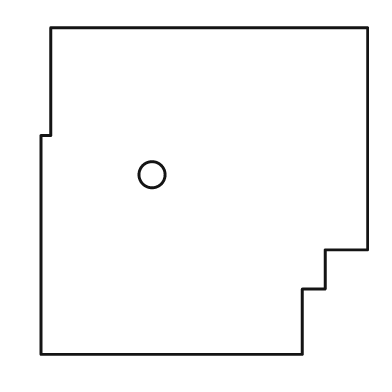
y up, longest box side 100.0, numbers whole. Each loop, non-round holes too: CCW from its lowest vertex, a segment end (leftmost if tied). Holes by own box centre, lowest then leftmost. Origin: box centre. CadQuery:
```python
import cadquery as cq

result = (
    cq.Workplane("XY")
    .moveTo(-50.0, -50.0)
    .lineTo(30.0, -50.0)
    .lineTo(30.0, -30.0)
    .lineTo(37.0, -30.0)
    .lineTo(37.0, -18.0)
    .lineTo(50.0, -18.0)
    .lineTo(50.0, 50.0)
    .lineTo(-47.0, 50.0)
    .lineTo(-47.0, 17.0)
    .lineTo(-50.0, 17.0)
    .close()
    .moveTo(-16.0, 5.0)
    .circle(4.0)
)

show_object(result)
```